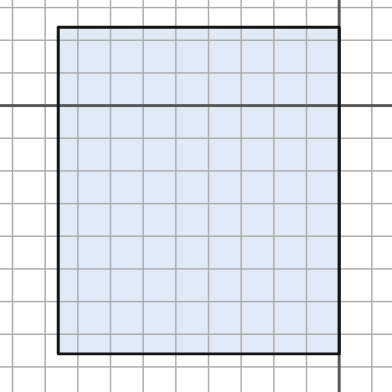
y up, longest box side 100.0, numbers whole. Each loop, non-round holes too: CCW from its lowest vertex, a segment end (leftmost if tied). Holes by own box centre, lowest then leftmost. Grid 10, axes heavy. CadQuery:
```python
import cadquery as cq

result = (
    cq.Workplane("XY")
    .moveTo(-86.0, -76.0)
    .lineTo(0.0, -76.0)
    .lineTo(0.0, 24.0)
    .lineTo(-86.0, 24.0)
    .close()
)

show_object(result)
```